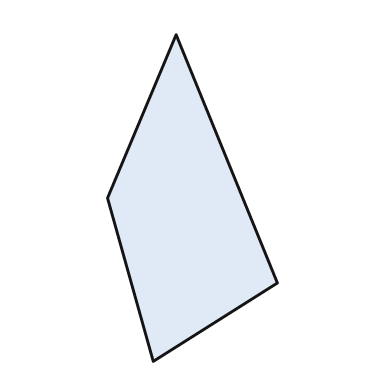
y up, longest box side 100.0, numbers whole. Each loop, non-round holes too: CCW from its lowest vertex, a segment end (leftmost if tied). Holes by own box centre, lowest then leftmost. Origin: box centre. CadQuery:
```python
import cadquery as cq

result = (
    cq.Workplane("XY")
    .moveTo(-12.0, -50.0)
    .lineTo(26.0, -26.0)
    .lineTo(-5.0, 50.0)
    .lineTo(-26.0, 0.0)
    .close()
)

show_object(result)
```